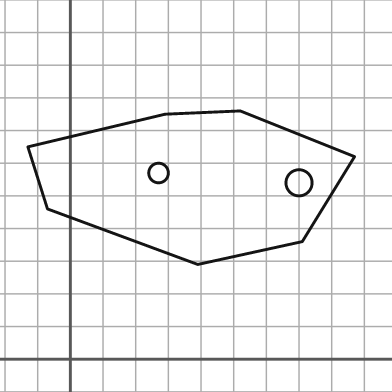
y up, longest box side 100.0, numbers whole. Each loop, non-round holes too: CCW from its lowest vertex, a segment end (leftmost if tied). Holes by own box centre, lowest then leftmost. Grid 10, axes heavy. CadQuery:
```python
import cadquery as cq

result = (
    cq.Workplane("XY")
    .moveTo(39.0, 29.0)
    .lineTo(71.0, 36.0)
    .lineTo(87.0, 62.0)
    .lineTo(52.0, 76.0)
    .lineTo(29.0, 75.0)
    .lineTo(-13.0, 65.0)
    .lineTo(-7.0, 46.0)
    .close()
    .moveTo(70.0, 54.0)
    .circle(4.0)
    .moveTo(27.0, 57.0)
    .circle(3.0)
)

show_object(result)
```